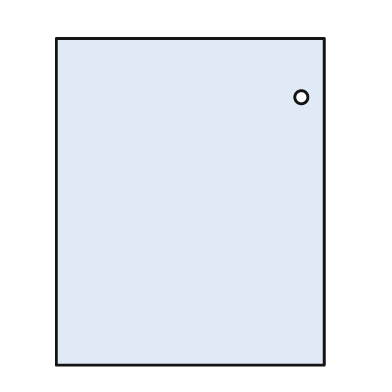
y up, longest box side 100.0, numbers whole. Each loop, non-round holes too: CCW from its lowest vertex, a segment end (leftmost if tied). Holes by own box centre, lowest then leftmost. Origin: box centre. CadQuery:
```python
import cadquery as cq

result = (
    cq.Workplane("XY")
    .moveTo(-41.0, -50.0)
    .lineTo(41.0, -50.0)
    .lineTo(41.0, 50.0)
    .lineTo(-41.0, 50.0)
    .close()
    .moveTo(34.0, 32.0)
    .circle(2.0)
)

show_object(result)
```